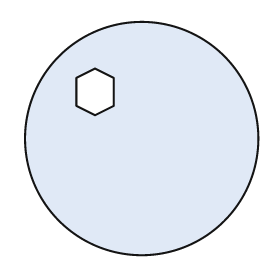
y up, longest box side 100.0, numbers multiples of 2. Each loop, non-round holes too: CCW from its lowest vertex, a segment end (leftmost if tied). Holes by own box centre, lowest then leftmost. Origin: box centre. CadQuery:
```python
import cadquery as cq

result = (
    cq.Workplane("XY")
    .moveTo(0.0, 0.0)
    .circle(50.0)
    .moveTo(-20.0, 10.0)
    .lineTo(-12.0, 14.0)
    .lineTo(-12.0, 26.0)
    .lineTo(-20.0, 30.0)
    .lineTo(-28.0, 26.0)
    .lineTo(-28.0, 14.0)
    .close()
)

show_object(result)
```